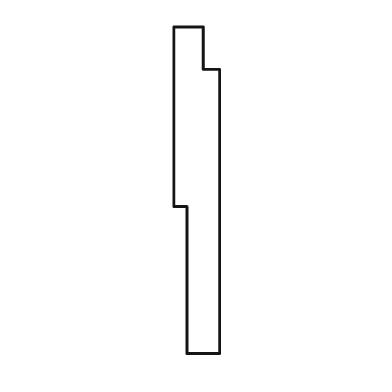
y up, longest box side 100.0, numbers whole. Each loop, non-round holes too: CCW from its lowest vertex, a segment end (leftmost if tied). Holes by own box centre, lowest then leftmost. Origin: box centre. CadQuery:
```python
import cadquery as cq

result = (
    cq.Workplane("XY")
    .moveTo(-3.0, -50.0)
    .lineTo(7.0, -50.0)
    .lineTo(7.0, 37.0)
    .lineTo(2.0, 37.0)
    .lineTo(2.0, 50.0)
    .lineTo(-7.0, 50.0)
    .lineTo(-7.0, -5.0)
    .lineTo(-3.0, -5.0)
    .close()
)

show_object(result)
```